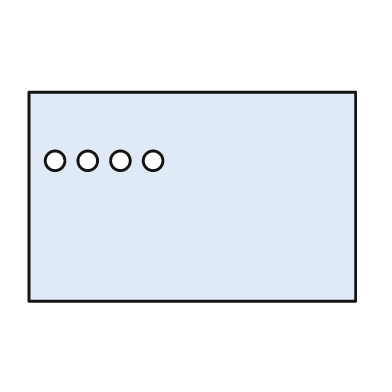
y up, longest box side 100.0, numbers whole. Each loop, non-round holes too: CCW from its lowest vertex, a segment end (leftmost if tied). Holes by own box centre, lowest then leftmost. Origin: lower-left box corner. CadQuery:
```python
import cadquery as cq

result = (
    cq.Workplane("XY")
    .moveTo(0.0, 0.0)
    .lineTo(100.0, 0.0)
    .lineTo(100.0, 64.0)
    .lineTo(0.0, 64.0)
    .close()
    .moveTo(8.0, 43.0)
    .circle(3.0)
    .moveTo(18.0, 43.0)
    .circle(3.0)
    .moveTo(28.0, 43.0)
    .circle(3.0)
    .moveTo(38.0, 43.0)
    .circle(3.0)
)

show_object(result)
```